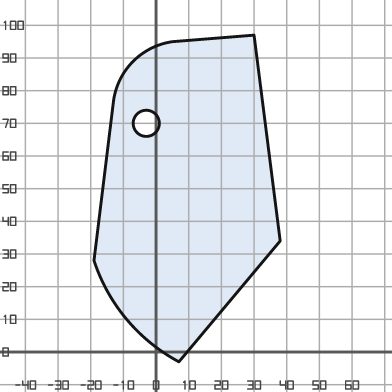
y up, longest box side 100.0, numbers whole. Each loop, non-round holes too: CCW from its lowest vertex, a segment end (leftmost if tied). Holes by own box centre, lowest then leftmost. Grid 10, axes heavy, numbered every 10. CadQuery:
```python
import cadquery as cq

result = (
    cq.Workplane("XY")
    .moveTo(7.0, -3.0)
    .lineTo(38.0, 34.0)
    .lineTo(30.0, 97.0)
    .lineTo(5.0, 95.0)
    .threePointArc((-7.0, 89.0), (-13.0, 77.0))
    .lineTo(-19.0, 28.0)
    .threePointArc((-9.0, 10.0), (7.0, -3.0))
    .close()
    .moveTo(-3.0, 70.0)
    .circle(4.0)
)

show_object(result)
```